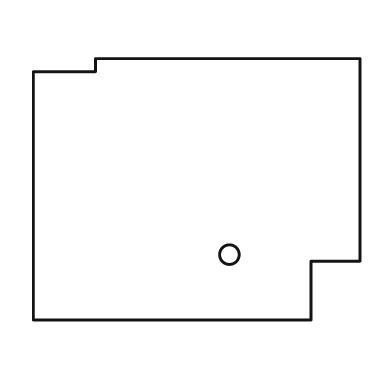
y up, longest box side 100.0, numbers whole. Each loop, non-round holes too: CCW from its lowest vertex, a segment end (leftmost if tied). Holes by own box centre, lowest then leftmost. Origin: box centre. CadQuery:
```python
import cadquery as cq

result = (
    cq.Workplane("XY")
    .moveTo(-50.0, -40.0)
    .lineTo(35.0, -40.0)
    .lineTo(35.0, -22.0)
    .lineTo(50.0, -22.0)
    .lineTo(50.0, 40.0)
    .lineTo(-31.0, 40.0)
    .lineTo(-31.0, 36.0)
    .lineTo(-50.0, 36.0)
    .close()
    .moveTo(10.0, -20.0)
    .circle(3.0)
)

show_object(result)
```